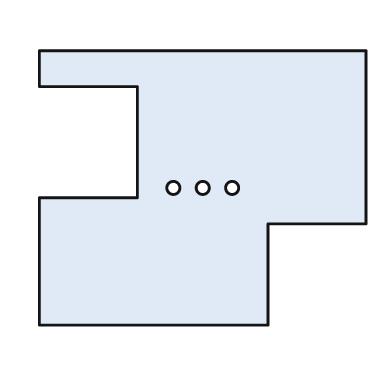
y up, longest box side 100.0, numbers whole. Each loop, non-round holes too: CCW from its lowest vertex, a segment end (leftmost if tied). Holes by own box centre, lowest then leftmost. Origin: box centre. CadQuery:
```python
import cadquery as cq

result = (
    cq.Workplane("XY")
    .moveTo(-50.0, -42.0)
    .lineTo(20.0, -42.0)
    .lineTo(20.0, -11.0)
    .lineTo(50.0, -11.0)
    .lineTo(50.0, 42.0)
    .lineTo(-50.0, 42.0)
    .lineTo(-50.0, 31.0)
    .lineTo(-20.0, 31.0)
    .lineTo(-20.0, -3.0)
    .lineTo(-50.0, -3.0)
    .close()
    .moveTo(-9.0, 0.0)
    .circle(2.0)
    .moveTo(0.0, 0.0)
    .circle(2.0)
    .moveTo(9.0, 0.0)
    .circle(2.0)
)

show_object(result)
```